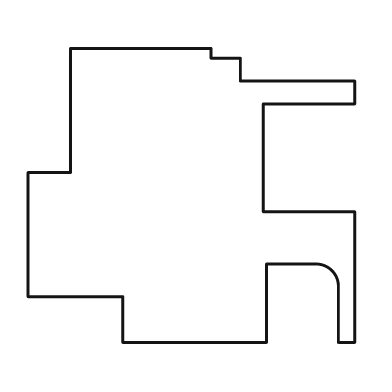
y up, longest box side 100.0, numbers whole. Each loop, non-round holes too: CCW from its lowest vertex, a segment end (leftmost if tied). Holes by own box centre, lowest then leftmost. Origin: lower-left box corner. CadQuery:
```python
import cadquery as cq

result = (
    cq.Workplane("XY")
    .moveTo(29.0, 0.0)
    .lineTo(73.0, 0.0)
    .lineTo(73.0, 24.0)
    .lineTo(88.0, 24.0)
    .threePointArc((93.0, 22.0), (95.0, 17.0))
    .lineTo(95.0, 0.0)
    .lineTo(100.0, 0.0)
    .lineTo(100.0, 40.0)
    .lineTo(72.0, 40.0)
    .lineTo(72.0, 73.0)
    .lineTo(100.0, 73.0)
    .lineTo(100.0, 80.0)
    .lineTo(65.0, 80.0)
    .lineTo(65.0, 87.0)
    .lineTo(56.0, 87.0)
    .lineTo(56.0, 90.0)
    .lineTo(13.0, 90.0)
    .lineTo(13.0, 52.0)
    .lineTo(0.0, 52.0)
    .lineTo(0.0, 14.0)
    .lineTo(29.0, 14.0)
    .close()
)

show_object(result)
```